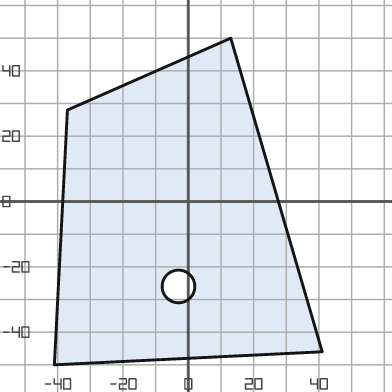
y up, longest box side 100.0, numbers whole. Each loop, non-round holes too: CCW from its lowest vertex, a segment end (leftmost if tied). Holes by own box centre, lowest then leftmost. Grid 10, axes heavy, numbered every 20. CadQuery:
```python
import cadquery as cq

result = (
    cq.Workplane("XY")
    .moveTo(-41.0, -50.0)
    .lineTo(41.0, -46.0)
    .lineTo(13.0, 50.0)
    .lineTo(-37.0, 28.0)
    .close()
    .moveTo(-3.0, -26.0)
    .circle(5.0)
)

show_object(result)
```